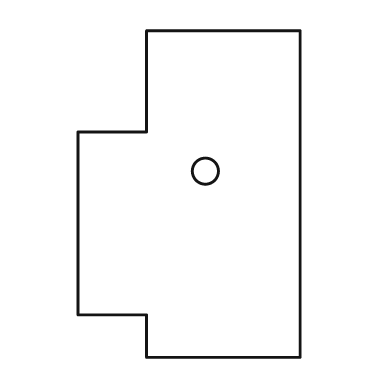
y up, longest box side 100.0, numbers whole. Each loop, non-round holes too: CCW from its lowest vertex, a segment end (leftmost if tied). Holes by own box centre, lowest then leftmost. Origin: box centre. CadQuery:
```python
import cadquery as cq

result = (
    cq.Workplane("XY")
    .moveTo(-13.0, -50.0)
    .lineTo(34.0, -50.0)
    .lineTo(34.0, 50.0)
    .lineTo(-13.0, 50.0)
    .lineTo(-13.0, 19.0)
    .lineTo(-34.0, 19.0)
    .lineTo(-34.0, -37.0)
    .lineTo(-13.0, -37.0)
    .close()
    .moveTo(5.0, 7.0)
    .circle(4.0)
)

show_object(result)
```